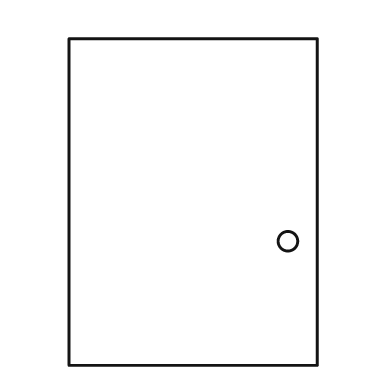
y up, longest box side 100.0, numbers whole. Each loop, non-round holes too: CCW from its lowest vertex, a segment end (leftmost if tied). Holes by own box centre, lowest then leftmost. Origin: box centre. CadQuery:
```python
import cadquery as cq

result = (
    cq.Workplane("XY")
    .moveTo(-38.0, -50.0)
    .lineTo(38.0, -50.0)
    .lineTo(38.0, 50.0)
    .lineTo(-38.0, 50.0)
    .close()
    .moveTo(29.0, -12.0)
    .circle(3.0)
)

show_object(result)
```